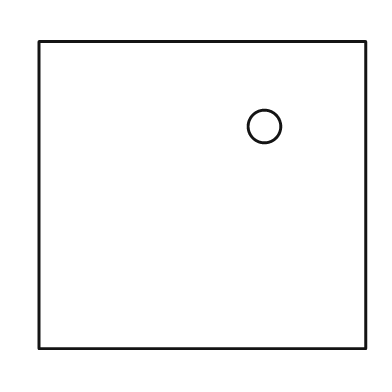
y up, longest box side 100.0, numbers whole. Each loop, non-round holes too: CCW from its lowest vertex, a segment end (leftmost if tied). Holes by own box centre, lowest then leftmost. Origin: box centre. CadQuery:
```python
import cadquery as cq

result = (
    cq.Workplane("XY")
    .moveTo(-50.0, -47.0)
    .lineTo(50.0, -47.0)
    .lineTo(50.0, 47.0)
    .lineTo(-50.0, 47.0)
    .close()
    .moveTo(19.0, 21.0)
    .circle(5.0)
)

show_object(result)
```